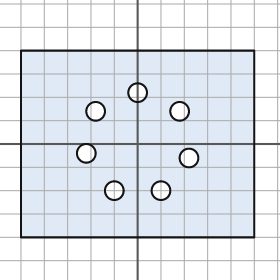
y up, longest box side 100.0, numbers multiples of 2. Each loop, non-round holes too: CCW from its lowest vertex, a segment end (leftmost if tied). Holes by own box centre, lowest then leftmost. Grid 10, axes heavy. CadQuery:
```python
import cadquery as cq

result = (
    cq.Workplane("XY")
    .moveTo(-50.0, -40.0)
    .lineTo(50.0, -40.0)
    .lineTo(50.0, 40.0)
    .lineTo(-50.0, 40.0)
    .close()
    .moveTo(-10.0, -20.0)
    .circle(4.0)
    .moveTo(10.0, -20.0)
    .circle(4.0)
    .moveTo(22.0, -6.0)
    .circle(4.0)
    .moveTo(-22.0, -4.0)
    .circle(4.0)
    .moveTo(-18.0, 14.0)
    .circle(4.0)
    .moveTo(18.0, 14.0)
    .circle(4.0)
    .moveTo(0.0, 22.0)
    .circle(4.0)
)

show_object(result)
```